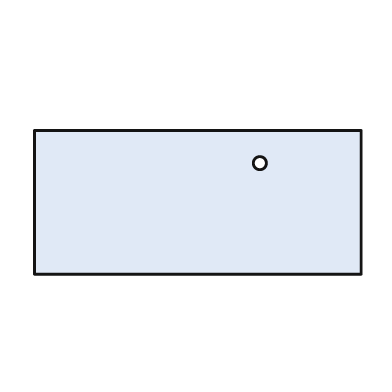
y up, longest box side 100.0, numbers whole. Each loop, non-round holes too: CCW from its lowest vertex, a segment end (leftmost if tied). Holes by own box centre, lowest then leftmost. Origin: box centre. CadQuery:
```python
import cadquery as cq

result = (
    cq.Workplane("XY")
    .moveTo(-50.0, -22.0)
    .lineTo(50.0, -22.0)
    .lineTo(50.0, 22.0)
    .lineTo(-50.0, 22.0)
    .close()
    .moveTo(19.0, 12.0)
    .circle(2.0)
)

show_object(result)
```